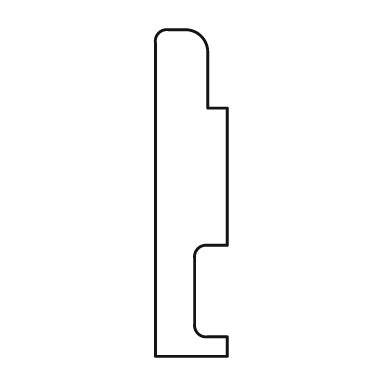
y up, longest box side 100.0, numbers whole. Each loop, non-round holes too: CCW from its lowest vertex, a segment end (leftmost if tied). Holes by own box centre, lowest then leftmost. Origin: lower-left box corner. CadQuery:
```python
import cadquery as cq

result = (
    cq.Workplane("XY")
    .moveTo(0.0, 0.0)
    .lineTo(22.0, 0.0)
    .lineTo(22.0, 6.0)
    .lineTo(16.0, 6.0)
    .threePointArc((13.0, 7.0), (12.0, 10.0))
    .lineTo(12.0, 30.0)
    .threePointArc((13.0, 33.0), (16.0, 34.0))
    .lineTo(22.0, 34.0)
    .lineTo(22.0, 76.0)
    .lineTo(16.0, 76.0)
    .lineTo(16.0, 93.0)
    .threePointArc((14.0, 98.0), (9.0, 100.0))
    .lineTo(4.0, 100.0)
    .threePointArc((1.0, 99.0), (0.0, 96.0))
    .close()
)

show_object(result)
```